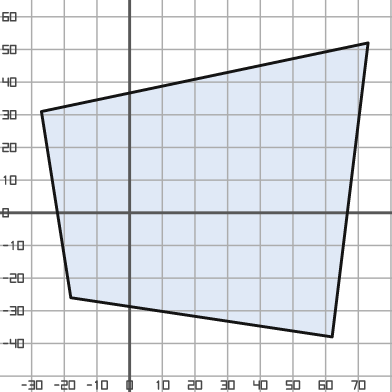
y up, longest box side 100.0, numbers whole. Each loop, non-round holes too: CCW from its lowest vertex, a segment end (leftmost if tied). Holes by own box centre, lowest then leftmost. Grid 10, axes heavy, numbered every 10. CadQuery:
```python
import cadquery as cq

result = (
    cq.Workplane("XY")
    .moveTo(62.0, -38.0)
    .lineTo(73.0, 52.0)
    .lineTo(-27.0, 31.0)
    .lineTo(-18.0, -26.0)
    .close()
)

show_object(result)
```